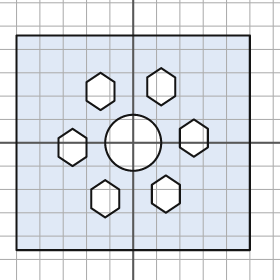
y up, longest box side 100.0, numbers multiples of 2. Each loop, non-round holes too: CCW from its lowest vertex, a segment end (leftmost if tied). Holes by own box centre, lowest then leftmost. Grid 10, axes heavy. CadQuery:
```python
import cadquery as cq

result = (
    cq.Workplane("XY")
    .moveTo(-50.0, -46.0)
    .lineTo(50.0, -46.0)
    .lineTo(50.0, 46.0)
    .lineTo(-50.0, 46.0)
    .close()
    .moveTo(-12.0, -32.0)
    .lineTo(-6.0, -28.0)
    .lineTo(-6.0, -20.0)
    .lineTo(-12.0, -16.0)
    .lineTo(-18.0, -20.0)
    .lineTo(-18.0, -28.0)
    .close()
    .moveTo(14.0, -30.0)
    .lineTo(20.0, -26.0)
    .lineTo(20.0, -18.0)
    .lineTo(14.0, -14.0)
    .lineTo(8.0, -18.0)
    .lineTo(8.0, -26.0)
    .close()
    .moveTo(-26.0, -10.0)
    .lineTo(-20.0, -6.0)
    .lineTo(-20.0, 2.0)
    .lineTo(-26.0, 6.0)
    .lineTo(-32.0, 2.0)
    .lineTo(-32.0, -6.0)
    .close()
    .moveTo(0.0, 0.0)
    .circle(12.0)
    .moveTo(26.0, -6.0)
    .lineTo(32.0, -2.0)
    .lineTo(32.0, 6.0)
    .lineTo(26.0, 10.0)
    .lineTo(20.0, 6.0)
    .lineTo(20.0, -2.0)
    .close()
    .moveTo(-14.0, 14.0)
    .lineTo(-8.0, 18.0)
    .lineTo(-8.0, 26.0)
    .lineTo(-14.0, 30.0)
    .lineTo(-20.0, 26.0)
    .lineTo(-20.0, 18.0)
    .close()
    .moveTo(12.0, 16.0)
    .lineTo(18.0, 20.0)
    .lineTo(18.0, 28.0)
    .lineTo(12.0, 32.0)
    .lineTo(6.0, 28.0)
    .lineTo(6.0, 20.0)
    .close()
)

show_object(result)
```